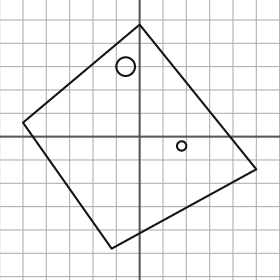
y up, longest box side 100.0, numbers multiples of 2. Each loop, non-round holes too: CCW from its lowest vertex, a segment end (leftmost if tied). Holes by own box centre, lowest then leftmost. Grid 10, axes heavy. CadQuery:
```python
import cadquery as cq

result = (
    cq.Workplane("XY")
    .moveTo(-12.0, -48.0)
    .lineTo(50.0, -14.0)
    .lineTo(0.0, 48.0)
    .lineTo(-50.0, 6.0)
    .close()
    .moveTo(18.0, -4.0)
    .circle(2.0)
    .moveTo(-6.0, 30.0)
    .circle(4.0)
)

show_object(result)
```